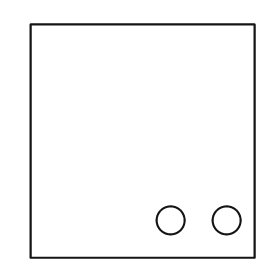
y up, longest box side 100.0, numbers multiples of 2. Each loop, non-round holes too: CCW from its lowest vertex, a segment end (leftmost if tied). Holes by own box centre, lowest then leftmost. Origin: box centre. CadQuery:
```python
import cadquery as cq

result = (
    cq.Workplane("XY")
    .moveTo(-48.0, -50.0)
    .lineTo(48.0, -50.0)
    .lineTo(48.0, 50.0)
    .lineTo(-48.0, 50.0)
    .close()
    .moveTo(12.0, -34.0)
    .circle(6.0)
    .moveTo(36.0, -34.0)
    .circle(6.0)
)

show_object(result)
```